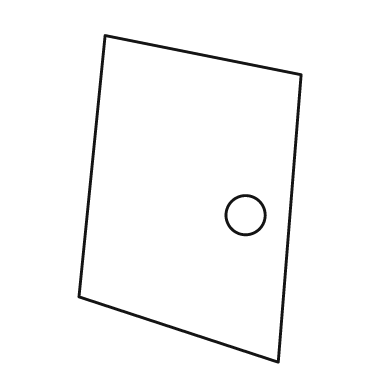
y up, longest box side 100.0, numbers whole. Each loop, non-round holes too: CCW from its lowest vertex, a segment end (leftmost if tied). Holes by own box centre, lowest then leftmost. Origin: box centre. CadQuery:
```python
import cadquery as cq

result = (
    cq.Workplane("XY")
    .moveTo(27.0, -50.0)
    .lineTo(34.0, 38.0)
    .lineTo(-26.0, 50.0)
    .lineTo(-34.0, -30.0)
    .close()
    .moveTo(17.0, -5.0)
    .circle(6.0)
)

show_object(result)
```